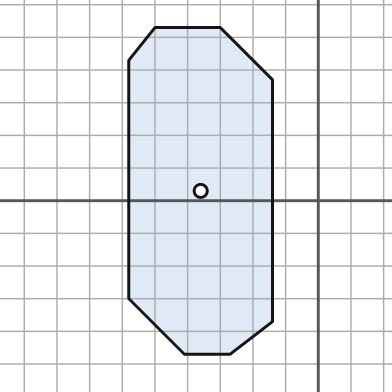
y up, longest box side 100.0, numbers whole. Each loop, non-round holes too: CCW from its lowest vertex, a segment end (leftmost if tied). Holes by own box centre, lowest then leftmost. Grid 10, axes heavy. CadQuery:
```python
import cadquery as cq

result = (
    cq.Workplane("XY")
    .moveTo(-41.0, -47.0)
    .lineTo(-27.0, -47.0)
    .lineTo(-14.0, -37.0)
    .lineTo(-14.0, 37.0)
    .lineTo(-30.0, 53.0)
    .lineTo(-50.0, 53.0)
    .lineTo(-58.0, 43.0)
    .lineTo(-58.0, -30.0)
    .close()
    .moveTo(-36.0, 3.0)
    .circle(2.0)
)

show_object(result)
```